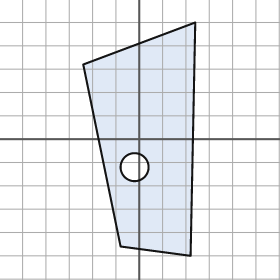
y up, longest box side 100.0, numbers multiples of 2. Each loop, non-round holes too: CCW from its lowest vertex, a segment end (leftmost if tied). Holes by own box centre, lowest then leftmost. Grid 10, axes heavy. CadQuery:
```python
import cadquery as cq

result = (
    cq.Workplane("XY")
    .moveTo(22.0, -50.0)
    .lineTo(24.0, 50.0)
    .lineTo(-24.0, 32.0)
    .lineTo(-8.0, -46.0)
    .close()
    .moveTo(-2.0, -12.0)
    .circle(6.0)
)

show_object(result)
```